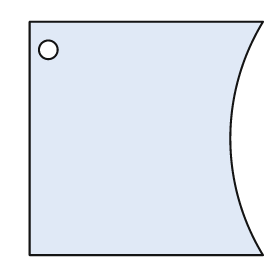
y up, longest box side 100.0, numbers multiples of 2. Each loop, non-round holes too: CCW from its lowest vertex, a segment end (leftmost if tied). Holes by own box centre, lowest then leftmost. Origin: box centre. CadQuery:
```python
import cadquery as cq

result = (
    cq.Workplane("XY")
    .moveTo(-50.0, -50.0)
    .lineTo(50.0, -50.0)
    .threePointArc((36.0, 0.0), (50.0, 50.0))
    .lineTo(-50.0, 50.0)
    .close()
    .moveTo(-42.0, 38.0)
    .circle(4.0)
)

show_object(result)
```